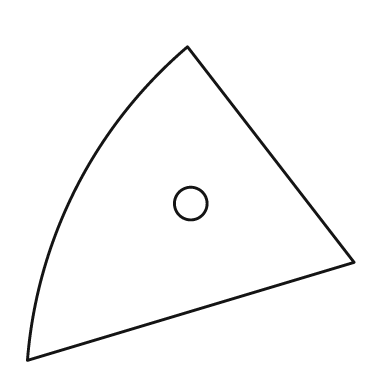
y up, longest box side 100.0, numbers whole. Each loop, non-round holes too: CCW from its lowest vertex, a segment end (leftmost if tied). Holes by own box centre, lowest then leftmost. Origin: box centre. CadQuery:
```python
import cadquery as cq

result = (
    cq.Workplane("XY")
    .moveTo(-50.0, -48.0)
    .lineTo(50.0, -18.0)
    .lineTo(-1.0, 48.0)
    .threePointArc((-35.0, 5.0), (-50.0, -48.0))
    .close()
    .moveTo(0.0, 0.0)
    .circle(5.0)
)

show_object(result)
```